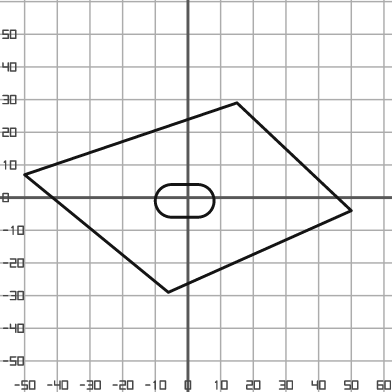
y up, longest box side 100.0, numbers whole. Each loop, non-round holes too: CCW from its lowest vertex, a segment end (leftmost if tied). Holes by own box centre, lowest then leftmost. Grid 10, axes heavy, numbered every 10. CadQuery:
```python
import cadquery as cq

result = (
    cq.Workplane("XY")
    .moveTo(-6.0, -29.0)
    .lineTo(50.0, -4.0)
    .lineTo(15.0, 29.0)
    .lineTo(-50.0, 7.0)
    .close()
    .moveTo(-5.0, -6.0)
    .lineTo(3.0, -6.0)
    .threePointArc((8.0, -1.0), (3.0, 4.0))
    .lineTo(-5.0, 4.0)
    .threePointArc((-10.0, -1.0), (-5.0, -6.0))
    .close()
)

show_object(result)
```